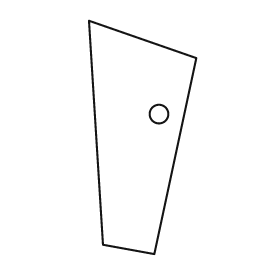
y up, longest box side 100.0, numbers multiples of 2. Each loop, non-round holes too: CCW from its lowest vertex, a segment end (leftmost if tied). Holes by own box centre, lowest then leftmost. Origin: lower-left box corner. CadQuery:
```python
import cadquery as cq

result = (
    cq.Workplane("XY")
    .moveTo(28.0, 0.0)
    .lineTo(46.0, 84.0)
    .lineTo(0.0, 100.0)
    .lineTo(6.0, 4.0)
    .close()
    .moveTo(30.0, 60.0)
    .circle(4.0)
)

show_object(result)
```